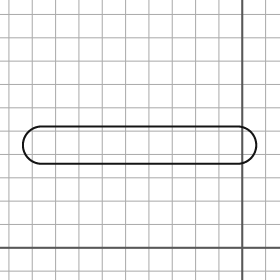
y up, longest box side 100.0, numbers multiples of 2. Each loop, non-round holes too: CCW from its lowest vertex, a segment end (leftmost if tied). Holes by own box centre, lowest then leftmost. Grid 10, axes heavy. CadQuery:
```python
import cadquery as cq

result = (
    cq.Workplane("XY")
    .moveTo(-86.0, 36.0)
    .lineTo(-2.0, 36.0)
    .threePointArc((6.0, 44.0), (-2.0, 52.0))
    .lineTo(-86.0, 52.0)
    .threePointArc((-94.0, 44.0), (-86.0, 36.0))
    .close()
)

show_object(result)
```